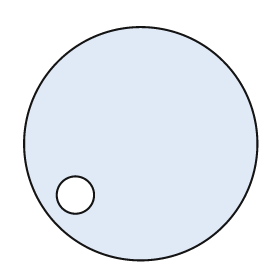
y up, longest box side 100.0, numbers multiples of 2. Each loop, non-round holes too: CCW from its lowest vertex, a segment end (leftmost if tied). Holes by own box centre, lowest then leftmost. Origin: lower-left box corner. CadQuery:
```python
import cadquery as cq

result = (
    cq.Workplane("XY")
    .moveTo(50.0, 50.0)
    .circle(50.0)
    .moveTo(22.0, 28.0)
    .circle(8.0)
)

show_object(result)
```